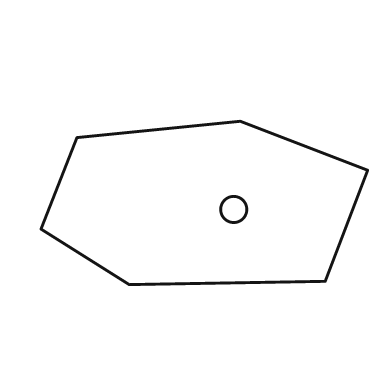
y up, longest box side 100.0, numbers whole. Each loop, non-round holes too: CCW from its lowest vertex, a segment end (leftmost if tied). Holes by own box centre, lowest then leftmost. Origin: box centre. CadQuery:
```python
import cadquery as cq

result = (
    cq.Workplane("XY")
    .moveTo(-23.0, -25.0)
    .lineTo(37.0, -24.0)
    .lineTo(50.0, 10.0)
    .lineTo(11.0, 25.0)
    .lineTo(-39.0, 20.0)
    .lineTo(-50.0, -8.0)
    .close()
    .moveTo(9.0, -2.0)
    .circle(4.0)
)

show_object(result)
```